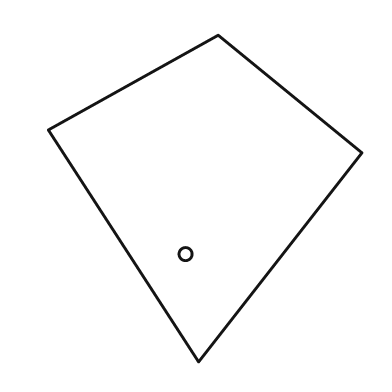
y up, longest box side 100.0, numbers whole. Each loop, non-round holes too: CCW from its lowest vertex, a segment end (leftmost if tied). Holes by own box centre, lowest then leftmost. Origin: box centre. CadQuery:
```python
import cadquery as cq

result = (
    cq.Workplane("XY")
    .moveTo(-2.0, -50.0)
    .lineTo(48.0, 14.0)
    .lineTo(4.0, 50.0)
    .lineTo(-48.0, 21.0)
    .close()
    .moveTo(-6.0, -17.0)
    .circle(2.0)
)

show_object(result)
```